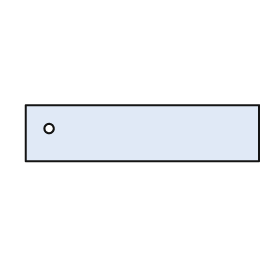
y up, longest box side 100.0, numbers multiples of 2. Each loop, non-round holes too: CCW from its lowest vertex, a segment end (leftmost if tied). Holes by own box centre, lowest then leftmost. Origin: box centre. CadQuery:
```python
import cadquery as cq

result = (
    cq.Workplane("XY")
    .moveTo(-50.0, -12.0)
    .lineTo(50.0, -12.0)
    .lineTo(50.0, 12.0)
    .lineTo(-50.0, 12.0)
    .close()
    .moveTo(-40.0, 2.0)
    .circle(2.0)
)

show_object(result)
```